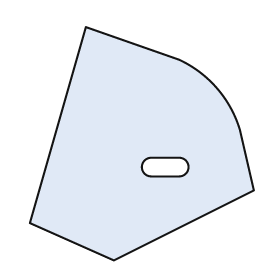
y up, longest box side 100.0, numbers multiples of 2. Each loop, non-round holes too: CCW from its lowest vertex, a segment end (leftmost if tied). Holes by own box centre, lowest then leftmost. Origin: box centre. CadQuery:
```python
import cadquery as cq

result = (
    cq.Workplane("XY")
    .moveTo(-12.0, -50.0)
    .lineTo(48.0, -20.0)
    .lineTo(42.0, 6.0)
    .threePointArc((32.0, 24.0), (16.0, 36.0))
    .lineTo(-24.0, 50.0)
    .lineTo(-48.0, -34.0)
    .close()
    .moveTo(4.0, -14.0)
    .lineTo(16.0, -14.0)
    .threePointArc((20.0, -10.0), (16.0, -6.0))
    .lineTo(4.0, -6.0)
    .threePointArc((0.0, -10.0), (4.0, -14.0))
    .close()
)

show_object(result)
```